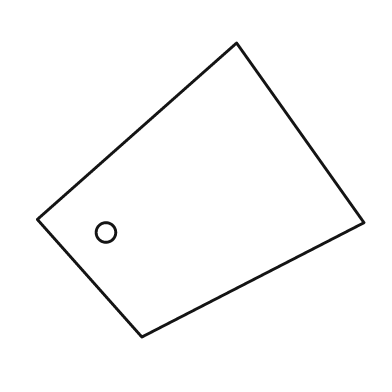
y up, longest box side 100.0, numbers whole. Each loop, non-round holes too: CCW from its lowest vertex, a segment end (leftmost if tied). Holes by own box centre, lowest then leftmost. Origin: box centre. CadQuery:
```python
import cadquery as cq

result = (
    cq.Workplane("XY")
    .moveTo(-18.0, -45.0)
    .lineTo(50.0, -10.0)
    .lineTo(11.0, 45.0)
    .lineTo(-50.0, -9.0)
    .close()
    .moveTo(-29.0, -13.0)
    .circle(3.0)
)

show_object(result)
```